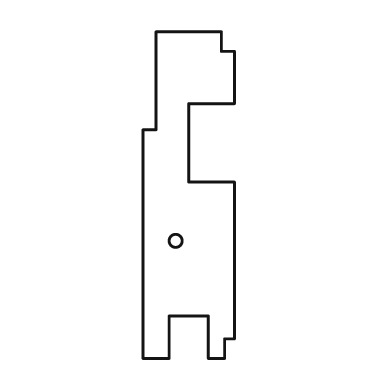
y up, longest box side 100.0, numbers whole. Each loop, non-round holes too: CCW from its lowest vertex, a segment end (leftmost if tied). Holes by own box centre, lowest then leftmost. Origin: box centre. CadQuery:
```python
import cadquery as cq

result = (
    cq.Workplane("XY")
    .moveTo(-14.0, -50.0)
    .lineTo(-6.0, -50.0)
    .lineTo(-6.0, -37.0)
    .lineTo(6.0, -37.0)
    .lineTo(6.0, -50.0)
    .lineTo(11.0, -50.0)
    .lineTo(11.0, -44.0)
    .lineTo(14.0, -44.0)
    .lineTo(14.0, 4.0)
    .lineTo(0.0, 4.0)
    .lineTo(0.0, 28.0)
    .lineTo(14.0, 28.0)
    .lineTo(14.0, 44.0)
    .lineTo(10.0, 44.0)
    .lineTo(10.0, 50.0)
    .lineTo(-10.0, 50.0)
    .lineTo(-10.0, 20.0)
    .lineTo(-14.0, 20.0)
    .close()
    .moveTo(-4.0, -14.0)
    .circle(2.0)
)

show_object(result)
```